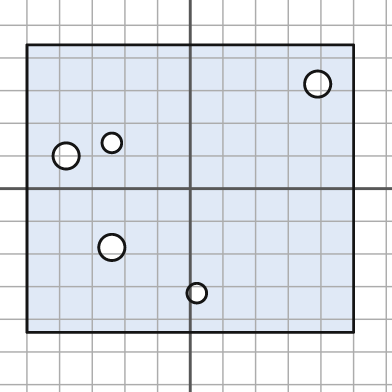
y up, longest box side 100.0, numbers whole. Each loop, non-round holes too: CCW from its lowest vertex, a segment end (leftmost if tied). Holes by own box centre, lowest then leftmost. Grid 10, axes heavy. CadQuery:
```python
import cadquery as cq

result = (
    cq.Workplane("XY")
    .moveTo(-50.0, -44.0)
    .lineTo(50.0, -44.0)
    .lineTo(50.0, 44.0)
    .lineTo(-50.0, 44.0)
    .close()
    .moveTo(2.0, -32.0)
    .circle(3.0)
    .moveTo(-24.0, -18.0)
    .circle(4.0)
    .moveTo(-38.0, 10.0)
    .circle(4.0)
    .moveTo(-24.0, 14.0)
    .circle(3.0)
    .moveTo(39.0, 32.0)
    .circle(4.0)
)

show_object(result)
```